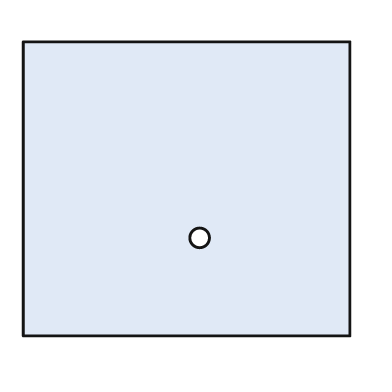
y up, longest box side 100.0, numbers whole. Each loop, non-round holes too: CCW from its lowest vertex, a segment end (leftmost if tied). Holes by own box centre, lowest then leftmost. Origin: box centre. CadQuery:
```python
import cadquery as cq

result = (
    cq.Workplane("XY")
    .moveTo(-50.0, -45.0)
    .lineTo(50.0, -45.0)
    .lineTo(50.0, 45.0)
    .lineTo(-50.0, 45.0)
    .close()
    .moveTo(4.0, -15.0)
    .circle(3.0)
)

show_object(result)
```